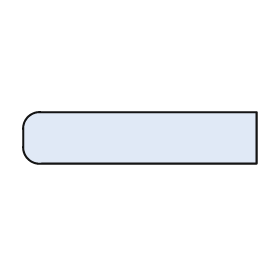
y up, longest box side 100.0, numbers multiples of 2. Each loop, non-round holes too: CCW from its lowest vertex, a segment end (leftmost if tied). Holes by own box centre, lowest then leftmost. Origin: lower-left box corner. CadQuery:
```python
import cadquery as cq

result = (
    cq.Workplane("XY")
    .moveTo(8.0, 0.0)
    .lineTo(100.0, 0.0)
    .lineTo(100.0, 22.0)
    .lineTo(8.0, 22.0)
    .threePointArc((2.0, 20.0), (0.0, 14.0))
    .lineTo(0.0, 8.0)
    .threePointArc((2.0, 2.0), (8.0, 0.0))
    .close()
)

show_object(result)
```